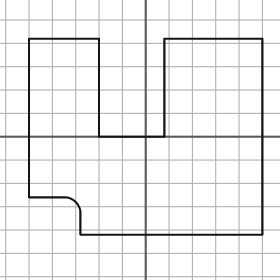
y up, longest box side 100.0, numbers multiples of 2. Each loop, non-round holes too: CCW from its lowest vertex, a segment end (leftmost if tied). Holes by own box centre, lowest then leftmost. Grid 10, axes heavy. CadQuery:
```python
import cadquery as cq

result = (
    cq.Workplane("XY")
    .moveTo(-28.0, -42.0)
    .lineTo(50.0, -42.0)
    .lineTo(50.0, 42.0)
    .lineTo(8.0, 42.0)
    .lineTo(8.0, 0.0)
    .lineTo(-20.0, 0.0)
    .lineTo(-20.0, 42.0)
    .lineTo(-50.0, 42.0)
    .lineTo(-50.0, -26.0)
    .lineTo(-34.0, -26.0)
    .threePointArc((-30.0, -28.0), (-28.0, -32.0))
    .close()
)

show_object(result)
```